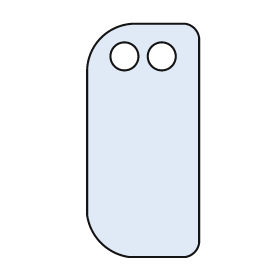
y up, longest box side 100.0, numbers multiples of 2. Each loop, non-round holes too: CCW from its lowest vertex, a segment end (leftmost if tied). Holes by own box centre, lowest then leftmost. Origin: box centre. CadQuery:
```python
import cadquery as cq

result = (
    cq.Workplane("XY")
    .moveTo(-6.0, -50.0)
    .lineTo(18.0, -50.0)
    .threePointArc((22.0, -48.0), (24.0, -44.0))
    .lineTo(24.0, 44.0)
    .threePointArc((22.0, 48.0), (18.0, 50.0))
    .lineTo(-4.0, 50.0)
    .threePointArc((-18.0, 44.0), (-24.0, 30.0))
    .lineTo(-24.0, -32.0)
    .threePointArc((-18.0, -44.0), (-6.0, -50.0))
    .close()
    .moveTo(-8.0, 36.0)
    .circle(6.0)
    .moveTo(8.0, 36.0)
    .circle(6.0)
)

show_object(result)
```